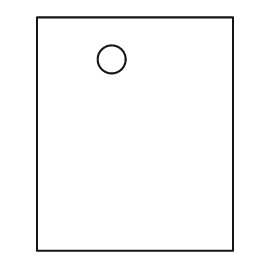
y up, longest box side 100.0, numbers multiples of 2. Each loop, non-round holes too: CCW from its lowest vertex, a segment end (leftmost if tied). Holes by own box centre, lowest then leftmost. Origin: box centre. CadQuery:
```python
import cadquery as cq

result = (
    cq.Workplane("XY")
    .moveTo(-42.0, -50.0)
    .lineTo(42.0, -50.0)
    .lineTo(42.0, 50.0)
    .lineTo(-42.0, 50.0)
    .close()
    .moveTo(-10.0, 32.0)
    .circle(6.0)
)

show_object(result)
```